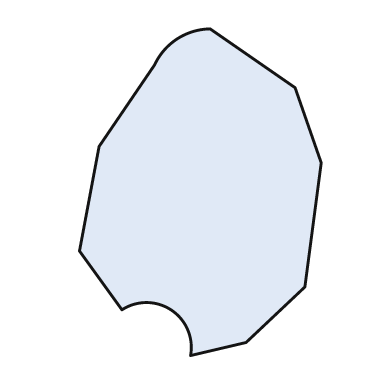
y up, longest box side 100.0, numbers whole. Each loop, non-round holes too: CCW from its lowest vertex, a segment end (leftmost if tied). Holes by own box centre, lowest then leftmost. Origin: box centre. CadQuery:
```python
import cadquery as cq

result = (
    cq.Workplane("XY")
    .moveTo(-3.0, -50.0)
    .lineTo(14.0, -46.0)
    .lineTo(32.0, -29.0)
    .lineTo(37.0, 9.0)
    .lineTo(29.0, 32.0)
    .lineTo(3.0, 50.0)
    .threePointArc((-7.0, 47.0), (-14.0, 39.0))
    .lineTo(-31.0, 14.0)
    .lineTo(-37.0, -18.0)
    .lineTo(-24.0, -36.0)
    .threePointArc((-9.0, -36.0), (-3.0, -50.0))
    .close()
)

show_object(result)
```